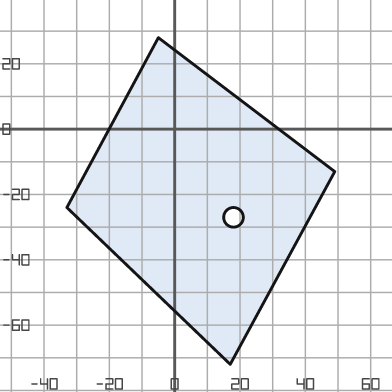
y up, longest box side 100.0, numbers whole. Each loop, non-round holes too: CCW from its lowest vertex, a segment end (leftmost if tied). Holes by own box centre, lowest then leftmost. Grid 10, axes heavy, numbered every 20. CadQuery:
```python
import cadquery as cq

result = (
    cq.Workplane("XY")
    .moveTo(17.0, -72.0)
    .lineTo(49.0, -13.0)
    .lineTo(-5.0, 28.0)
    .lineTo(-33.0, -24.0)
    .close()
    .moveTo(18.0, -27.0)
    .circle(3.0)
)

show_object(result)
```